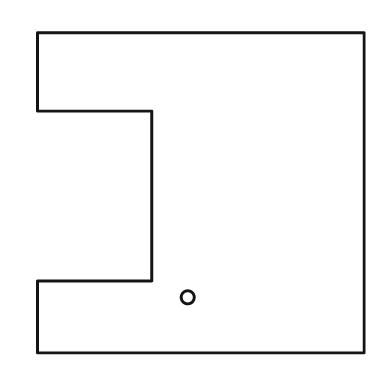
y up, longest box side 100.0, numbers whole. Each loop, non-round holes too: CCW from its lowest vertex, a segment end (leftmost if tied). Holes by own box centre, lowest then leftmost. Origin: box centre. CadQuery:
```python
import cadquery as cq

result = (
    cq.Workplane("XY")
    .moveTo(-50.0, -49.0)
    .lineTo(50.0, -49.0)
    .lineTo(50.0, 49.0)
    .lineTo(-50.0, 49.0)
    .lineTo(-50.0, 25.0)
    .lineTo(-15.0, 25.0)
    .lineTo(-15.0, -27.0)
    .lineTo(-50.0, -27.0)
    .close()
    .moveTo(-4.0, -32.0)
    .circle(2.0)
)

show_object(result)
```